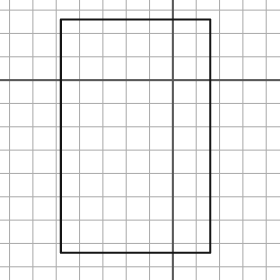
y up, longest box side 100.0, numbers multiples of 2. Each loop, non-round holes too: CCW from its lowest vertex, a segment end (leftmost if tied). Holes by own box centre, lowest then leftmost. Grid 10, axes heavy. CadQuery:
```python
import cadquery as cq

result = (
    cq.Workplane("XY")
    .moveTo(-48.0, -74.0)
    .lineTo(16.0, -74.0)
    .lineTo(16.0, 26.0)
    .lineTo(-48.0, 26.0)
    .close()
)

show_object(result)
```